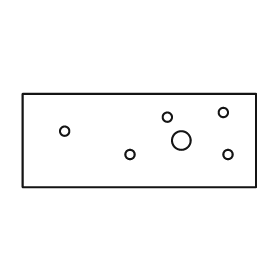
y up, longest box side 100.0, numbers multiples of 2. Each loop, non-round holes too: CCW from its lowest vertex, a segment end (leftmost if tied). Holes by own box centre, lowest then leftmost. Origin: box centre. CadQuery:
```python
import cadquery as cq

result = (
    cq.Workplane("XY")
    .moveTo(-50.0, -20.0)
    .lineTo(50.0, -20.0)
    .lineTo(50.0, 20.0)
    .lineTo(-50.0, 20.0)
    .close()
    .moveTo(-4.0, -6.0)
    .circle(2.0)
    .moveTo(38.0, -6.0)
    .circle(2.0)
    .moveTo(18.0, 0.0)
    .circle(4.0)
    .moveTo(-32.0, 4.0)
    .circle(2.0)
    .moveTo(12.0, 10.0)
    .circle(2.0)
    .moveTo(36.0, 12.0)
    .circle(2.0)
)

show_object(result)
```